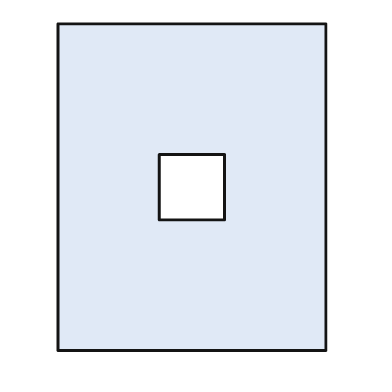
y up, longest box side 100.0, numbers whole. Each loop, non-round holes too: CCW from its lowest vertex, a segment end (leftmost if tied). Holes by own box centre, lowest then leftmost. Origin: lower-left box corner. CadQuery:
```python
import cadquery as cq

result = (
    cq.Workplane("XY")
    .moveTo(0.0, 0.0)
    .lineTo(82.0, 0.0)
    .lineTo(82.0, 100.0)
    .lineTo(0.0, 100.0)
    .close()
    .moveTo(31.0, 40.0)
    .lineTo(51.0, 40.0)
    .lineTo(51.0, 60.0)
    .lineTo(31.0, 60.0)
    .close()
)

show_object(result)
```